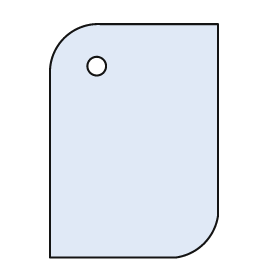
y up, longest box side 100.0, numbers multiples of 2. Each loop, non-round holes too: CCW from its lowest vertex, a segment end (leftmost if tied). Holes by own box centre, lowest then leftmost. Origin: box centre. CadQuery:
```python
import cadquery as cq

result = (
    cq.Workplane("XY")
    .moveTo(-36.0, -50.0)
    .lineTo(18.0, -50.0)
    .threePointArc((30.0, -44.0), (36.0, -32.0))
    .lineTo(36.0, 50.0)
    .lineTo(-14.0, 50.0)
    .threePointArc((-30.0, 44.0), (-36.0, 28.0))
    .close()
    .moveTo(-16.0, 32.0)
    .circle(4.0)
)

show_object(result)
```